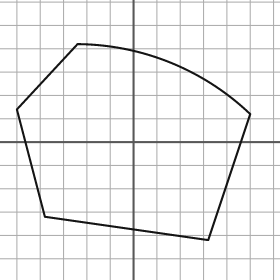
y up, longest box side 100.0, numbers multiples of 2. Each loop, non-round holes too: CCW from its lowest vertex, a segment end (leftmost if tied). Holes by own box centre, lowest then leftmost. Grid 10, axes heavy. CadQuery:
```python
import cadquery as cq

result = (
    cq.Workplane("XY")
    .moveTo(32.0, -42.0)
    .lineTo(50.0, 12.0)
    .threePointArc((16.0, 34.0), (-24.0, 42.0))
    .lineTo(-50.0, 14.0)
    .lineTo(-38.0, -32.0)
    .close()
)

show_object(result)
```